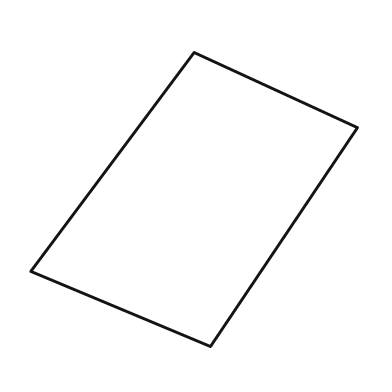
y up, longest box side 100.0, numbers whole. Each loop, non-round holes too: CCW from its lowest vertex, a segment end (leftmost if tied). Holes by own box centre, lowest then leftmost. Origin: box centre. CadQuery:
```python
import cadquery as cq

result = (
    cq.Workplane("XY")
    .moveTo(5.0, -45.0)
    .lineTo(50.0, 22.0)
    .lineTo(0.0, 45.0)
    .lineTo(-50.0, -22.0)
    .close()
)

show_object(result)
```